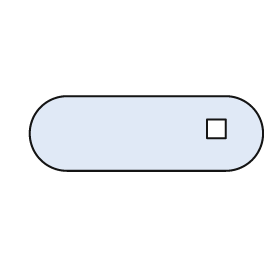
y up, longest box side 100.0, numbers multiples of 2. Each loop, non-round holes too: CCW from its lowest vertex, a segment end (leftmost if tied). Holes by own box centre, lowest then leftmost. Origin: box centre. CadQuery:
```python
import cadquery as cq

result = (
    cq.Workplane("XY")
    .moveTo(-34.0, -16.0)
    .lineTo(34.0, -16.0)
    .threePointArc((50.0, 0.0), (34.0, 16.0))
    .lineTo(-34.0, 16.0)
    .threePointArc((-50.0, 0.0), (-34.0, -16.0))
    .close()
    .moveTo(26.0, -2.0)
    .lineTo(34.0, -2.0)
    .lineTo(34.0, 6.0)
    .lineTo(26.0, 6.0)
    .close()
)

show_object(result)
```